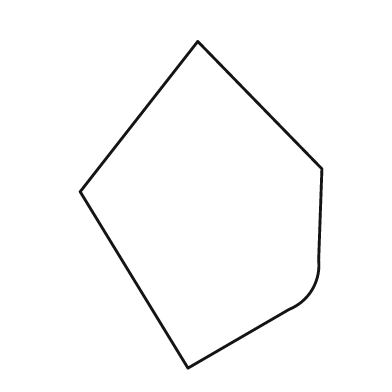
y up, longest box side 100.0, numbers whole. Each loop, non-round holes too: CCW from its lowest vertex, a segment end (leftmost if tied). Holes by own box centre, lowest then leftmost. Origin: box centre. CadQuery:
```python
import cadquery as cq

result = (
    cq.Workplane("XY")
    .moveTo(-4.0, -50.0)
    .lineTo(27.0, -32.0)
    .threePointArc((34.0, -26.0), (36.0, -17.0))
    .lineTo(37.0, 11.0)
    .lineTo(-1.0, 50.0)
    .lineTo(-37.0, 4.0)
    .close()
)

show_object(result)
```